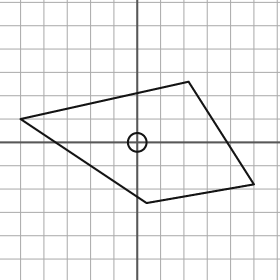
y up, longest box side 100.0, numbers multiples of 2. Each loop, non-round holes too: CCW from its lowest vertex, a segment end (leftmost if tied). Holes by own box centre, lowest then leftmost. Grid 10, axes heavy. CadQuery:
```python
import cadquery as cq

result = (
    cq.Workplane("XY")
    .moveTo(4.0, -26.0)
    .lineTo(50.0, -18.0)
    .lineTo(22.0, 26.0)
    .lineTo(-50.0, 10.0)
    .close()
    .moveTo(0.0, 0.0)
    .circle(4.0)
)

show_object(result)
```